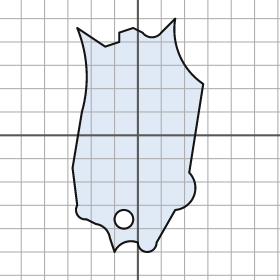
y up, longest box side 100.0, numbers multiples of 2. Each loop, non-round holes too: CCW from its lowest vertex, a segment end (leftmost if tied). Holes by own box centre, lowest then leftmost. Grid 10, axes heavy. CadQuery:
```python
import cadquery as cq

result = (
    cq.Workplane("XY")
    .moveTo(-10.0, -50.0)
    .threePointArc((-6.0, -46.0), (0.0, -46.0))
    .threePointArc((4.0, -50.0), (8.0, -46.0))
    .lineTo(16.0, -32.0)
    .threePointArc((24.0, -26.0), (22.0, -16.0))
    .lineTo(28.0, 22.0)
    .threePointArc((18.0, 34.0), (16.0, 50.0))
    .lineTo(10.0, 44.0)
    .threePointArc((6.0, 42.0), (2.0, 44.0))
    .lineTo(-2.0, 46.0)
    .lineTo(-8.0, 44.0)
    .lineTo(-8.0, 40.0)
    .lineTo(-14.0, 38.0)
    .lineTo(-26.0, 46.0)
    .threePointArc((-22.0, 28.0), (-24.0, 10.0))
    .lineTo(-28.0, -14.0)
    .lineTo(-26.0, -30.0)
    .threePointArc((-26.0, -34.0), (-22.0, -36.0))
    .lineTo(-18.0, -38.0)
    .threePointArc((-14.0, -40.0), (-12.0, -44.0))
    .close()
    .moveTo(-6.0, -36.0)
    .circle(4.0)
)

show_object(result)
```